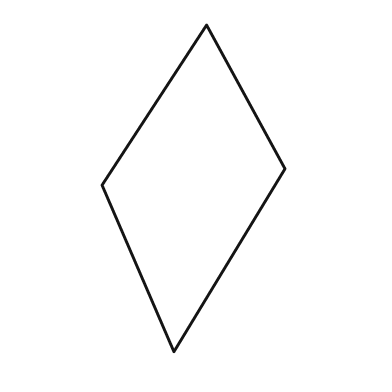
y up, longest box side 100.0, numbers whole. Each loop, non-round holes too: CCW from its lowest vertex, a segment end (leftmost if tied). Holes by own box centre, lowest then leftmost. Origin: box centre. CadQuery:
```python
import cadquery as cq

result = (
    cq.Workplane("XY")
    .moveTo(-6.0, -50.0)
    .lineTo(28.0, 6.0)
    .lineTo(4.0, 50.0)
    .lineTo(-28.0, 1.0)
    .close()
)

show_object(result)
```